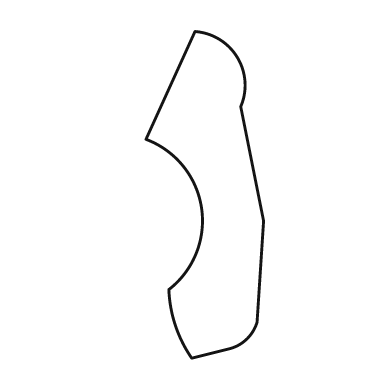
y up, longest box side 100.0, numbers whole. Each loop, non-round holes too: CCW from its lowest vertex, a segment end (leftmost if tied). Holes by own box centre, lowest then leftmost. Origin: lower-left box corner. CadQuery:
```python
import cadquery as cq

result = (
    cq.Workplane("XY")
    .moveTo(14.0, 0.0)
    .lineTo(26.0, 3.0)
    .threePointArc((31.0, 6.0), (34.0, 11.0))
    .lineTo(36.0, 42.0)
    .lineTo(29.0, 77.0)
    .threePointArc((28.0, 92.0), (15.0, 100.0))
    .lineTo(0.0, 67.0)
    .threePointArc((17.0, 46.0), (7.0, 21.0))
    .threePointArc((9.0, 10.0), (14.0, 0.0))
    .close()
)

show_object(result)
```